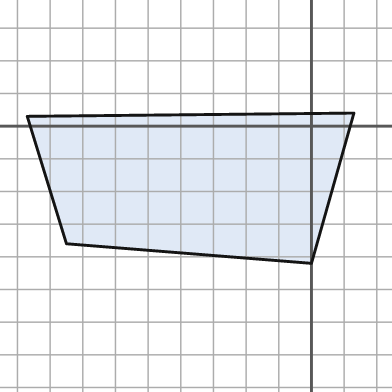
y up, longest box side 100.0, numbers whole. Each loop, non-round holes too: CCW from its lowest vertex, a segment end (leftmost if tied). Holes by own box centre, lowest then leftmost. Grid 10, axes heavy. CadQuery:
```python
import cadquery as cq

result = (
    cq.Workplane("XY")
    .moveTo(0.0, -42.0)
    .lineTo(13.0, 4.0)
    .lineTo(-87.0, 3.0)
    .lineTo(-75.0, -36.0)
    .close()
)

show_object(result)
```